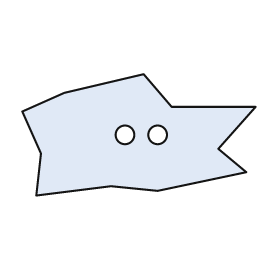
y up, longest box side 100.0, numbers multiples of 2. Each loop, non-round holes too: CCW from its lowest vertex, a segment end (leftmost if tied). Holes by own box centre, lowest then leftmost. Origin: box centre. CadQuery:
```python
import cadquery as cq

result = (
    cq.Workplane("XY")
    .moveTo(-44.0, -26.0)
    .lineTo(-12.0, -22.0)
    .lineTo(8.0, -24.0)
    .lineTo(46.0, -16.0)
    .lineTo(34.0, -6.0)
    .lineTo(50.0, 12.0)
    .lineTo(14.0, 12.0)
    .lineTo(2.0, 26.0)
    .lineTo(-32.0, 18.0)
    .lineTo(-50.0, 10.0)
    .lineTo(-42.0, -8.0)
    .close()
    .moveTo(-6.0, 0.0)
    .circle(4.0)
    .moveTo(8.0, 0.0)
    .circle(4.0)
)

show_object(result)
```